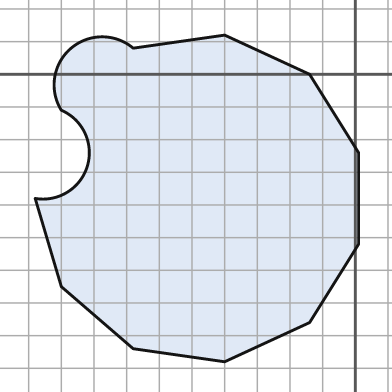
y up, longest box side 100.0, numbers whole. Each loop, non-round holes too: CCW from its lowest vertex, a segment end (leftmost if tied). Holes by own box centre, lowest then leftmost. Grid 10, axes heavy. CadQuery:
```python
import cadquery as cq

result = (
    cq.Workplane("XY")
    .moveTo(-40.0, -88.0)
    .lineTo(-14.0, -76.0)
    .lineTo(1.0, -52.0)
    .lineTo(1.0, -24.0)
    .lineTo(-14.0, 0.0)
    .lineTo(-40.0, 12.0)
    .lineTo(-68.0, 8.0)
    .threePointArc((-87.0, 8.0), (-90.0, -11.0))
    .threePointArc((-82.0, -28.0), (-98.0, -38.0))
    .lineTo(-90.0, -65.0)
    .lineTo(-68.0, -84.0)
    .close()
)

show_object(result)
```